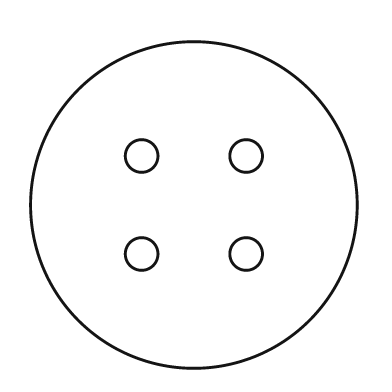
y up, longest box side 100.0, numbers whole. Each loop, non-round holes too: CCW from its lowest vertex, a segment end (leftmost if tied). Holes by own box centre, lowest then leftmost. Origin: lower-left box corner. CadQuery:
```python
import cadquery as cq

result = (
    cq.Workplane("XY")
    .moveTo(50.0, 50.0)
    .circle(50.0)
    .moveTo(34.0, 35.0)
    .circle(5.0)
    .moveTo(66.0, 35.0)
    .circle(5.0)
    .moveTo(34.0, 65.0)
    .circle(5.0)
    .moveTo(66.0, 65.0)
    .circle(5.0)
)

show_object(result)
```